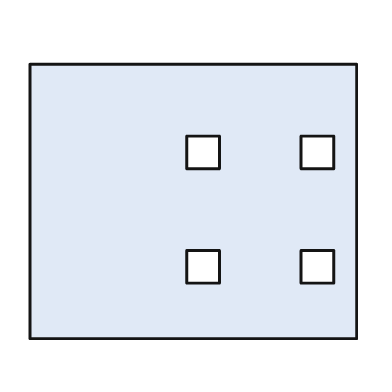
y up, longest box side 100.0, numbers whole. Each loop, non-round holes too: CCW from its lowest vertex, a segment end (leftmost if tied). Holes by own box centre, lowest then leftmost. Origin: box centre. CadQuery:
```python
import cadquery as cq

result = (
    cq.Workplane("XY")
    .moveTo(-50.0, -42.0)
    .lineTo(50.0, -42.0)
    .lineTo(50.0, 42.0)
    .lineTo(-50.0, 42.0)
    .close()
    .moveTo(-2.0, -25.0)
    .lineTo(8.0, -25.0)
    .lineTo(8.0, -15.0)
    .lineTo(-2.0, -15.0)
    .close()
    .moveTo(33.0, -25.0)
    .lineTo(43.0, -25.0)
    .lineTo(43.0, -15.0)
    .lineTo(33.0, -15.0)
    .close()
    .moveTo(-2.0, 10.0)
    .lineTo(8.0, 10.0)
    .lineTo(8.0, 20.0)
    .lineTo(-2.0, 20.0)
    .close()
    .moveTo(33.0, 10.0)
    .lineTo(43.0, 10.0)
    .lineTo(43.0, 20.0)
    .lineTo(33.0, 20.0)
    .close()
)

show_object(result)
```